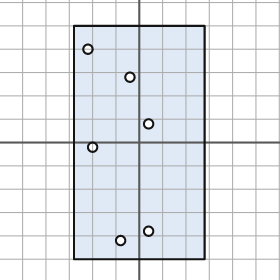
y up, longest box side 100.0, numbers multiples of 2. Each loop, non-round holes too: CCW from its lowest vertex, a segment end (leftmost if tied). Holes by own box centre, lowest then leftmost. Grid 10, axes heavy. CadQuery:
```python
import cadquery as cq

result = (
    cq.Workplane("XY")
    .moveTo(-28.0, -50.0)
    .lineTo(28.0, -50.0)
    .lineTo(28.0, 50.0)
    .lineTo(-28.0, 50.0)
    .close()
    .moveTo(-8.0, -42.0)
    .circle(2.0)
    .moveTo(4.0, -38.0)
    .circle(2.0)
    .moveTo(-20.0, -2.0)
    .circle(2.0)
    .moveTo(4.0, 8.0)
    .circle(2.0)
    .moveTo(-4.0, 28.0)
    .circle(2.0)
    .moveTo(-22.0, 40.0)
    .circle(2.0)
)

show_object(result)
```